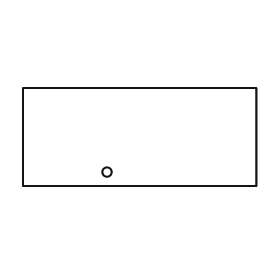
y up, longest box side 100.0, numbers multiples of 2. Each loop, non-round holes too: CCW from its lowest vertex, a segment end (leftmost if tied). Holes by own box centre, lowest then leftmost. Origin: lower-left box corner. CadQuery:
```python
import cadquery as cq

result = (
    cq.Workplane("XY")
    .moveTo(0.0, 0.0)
    .lineTo(100.0, 0.0)
    .lineTo(100.0, 42.0)
    .lineTo(0.0, 42.0)
    .close()
    .moveTo(36.0, 6.0)
    .circle(2.0)
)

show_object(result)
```